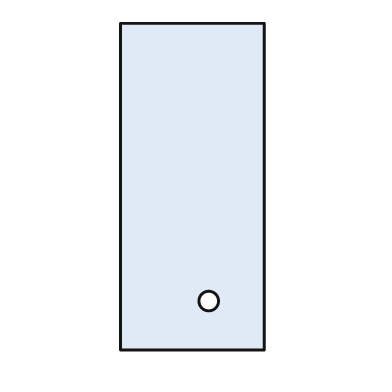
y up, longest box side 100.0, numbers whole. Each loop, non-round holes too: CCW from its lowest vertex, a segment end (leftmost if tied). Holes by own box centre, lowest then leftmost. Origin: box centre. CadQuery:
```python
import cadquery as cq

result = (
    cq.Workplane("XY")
    .moveTo(-22.0, -50.0)
    .lineTo(22.0, -50.0)
    .lineTo(22.0, 50.0)
    .lineTo(-22.0, 50.0)
    .close()
    .moveTo(5.0, -35.0)
    .circle(3.0)
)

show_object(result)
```